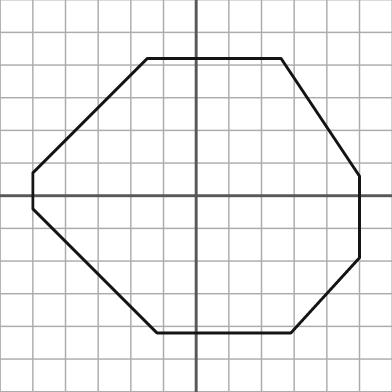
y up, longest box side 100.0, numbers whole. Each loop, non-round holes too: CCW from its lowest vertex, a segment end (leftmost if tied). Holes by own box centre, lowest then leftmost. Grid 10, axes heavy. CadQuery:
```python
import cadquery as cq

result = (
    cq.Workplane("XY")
    .moveTo(-12.0, -42.0)
    .lineTo(29.0, -42.0)
    .lineTo(50.0, -19.0)
    .lineTo(50.0, 6.0)
    .lineTo(26.0, 42.0)
    .lineTo(-15.0, 42.0)
    .lineTo(-50.0, 7.0)
    .lineTo(-50.0, -4.0)
    .close()
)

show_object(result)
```